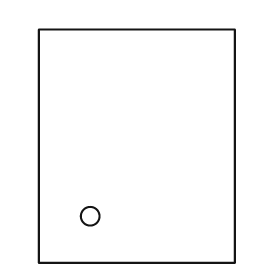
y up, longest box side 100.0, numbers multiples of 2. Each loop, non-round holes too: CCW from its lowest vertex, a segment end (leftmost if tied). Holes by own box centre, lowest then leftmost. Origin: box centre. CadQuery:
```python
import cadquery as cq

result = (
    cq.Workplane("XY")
    .moveTo(-42.0, -50.0)
    .lineTo(42.0, -50.0)
    .lineTo(42.0, 50.0)
    .lineTo(-42.0, 50.0)
    .close()
    .moveTo(-20.0, -30.0)
    .circle(4.0)
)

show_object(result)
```